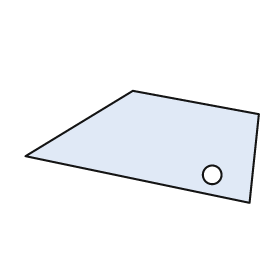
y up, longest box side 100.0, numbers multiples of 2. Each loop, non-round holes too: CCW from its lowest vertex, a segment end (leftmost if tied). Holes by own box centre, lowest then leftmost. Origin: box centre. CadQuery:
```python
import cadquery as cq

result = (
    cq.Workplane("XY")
    .moveTo(46.0, -24.0)
    .lineTo(50.0, 14.0)
    .lineTo(-4.0, 24.0)
    .lineTo(-50.0, -4.0)
    .close()
    .moveTo(30.0, -12.0)
    .circle(4.0)
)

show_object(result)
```